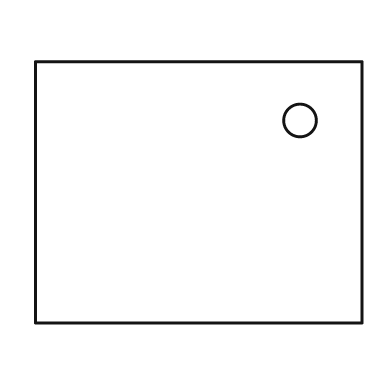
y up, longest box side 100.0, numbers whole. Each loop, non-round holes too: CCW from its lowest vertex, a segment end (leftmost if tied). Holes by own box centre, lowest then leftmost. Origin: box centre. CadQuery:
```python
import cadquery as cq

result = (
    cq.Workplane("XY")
    .moveTo(-50.0, -40.0)
    .lineTo(50.0, -40.0)
    .lineTo(50.0, 40.0)
    .lineTo(-50.0, 40.0)
    .close()
    .moveTo(31.0, 22.0)
    .circle(5.0)
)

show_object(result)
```